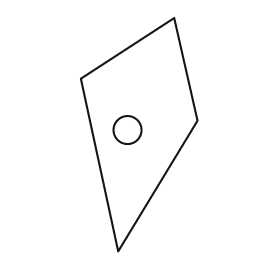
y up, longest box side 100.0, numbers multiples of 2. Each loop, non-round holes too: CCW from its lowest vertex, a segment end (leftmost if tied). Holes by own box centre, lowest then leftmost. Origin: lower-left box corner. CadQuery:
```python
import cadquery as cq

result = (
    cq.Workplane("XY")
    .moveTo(16.0, 0.0)
    .lineTo(50.0, 56.0)
    .lineTo(40.0, 100.0)
    .lineTo(0.0, 74.0)
    .close()
    .moveTo(20.0, 52.0)
    .circle(6.0)
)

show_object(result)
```